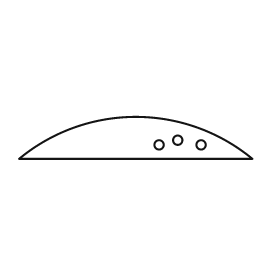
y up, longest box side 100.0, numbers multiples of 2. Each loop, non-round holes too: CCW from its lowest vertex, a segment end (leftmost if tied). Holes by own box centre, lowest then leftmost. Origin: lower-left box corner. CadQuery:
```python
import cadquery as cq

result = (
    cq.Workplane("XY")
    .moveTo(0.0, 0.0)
    .lineTo(100.0, 0.0)
    .threePointArc((50.0, 18.0), (0.0, 0.0))
    .close()
    .moveTo(60.0, 6.0)
    .circle(2.0)
    .moveTo(78.0, 6.0)
    .circle(2.0)
    .moveTo(68.0, 8.0)
    .circle(2.0)
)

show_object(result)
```